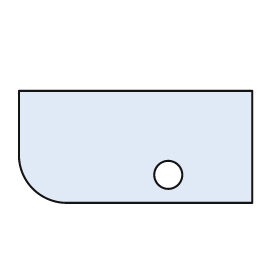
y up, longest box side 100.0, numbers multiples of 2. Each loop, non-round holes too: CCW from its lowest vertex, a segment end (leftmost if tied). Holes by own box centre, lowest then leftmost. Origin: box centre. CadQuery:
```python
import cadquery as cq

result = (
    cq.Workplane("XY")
    .moveTo(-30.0, -24.0)
    .lineTo(50.0, -24.0)
    .lineTo(50.0, 24.0)
    .lineTo(-50.0, 24.0)
    .lineTo(-50.0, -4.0)
    .threePointArc((-44.0, -18.0), (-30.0, -24.0))
    .close()
    .moveTo(14.0, -12.0)
    .circle(6.0)
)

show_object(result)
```